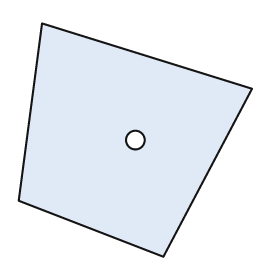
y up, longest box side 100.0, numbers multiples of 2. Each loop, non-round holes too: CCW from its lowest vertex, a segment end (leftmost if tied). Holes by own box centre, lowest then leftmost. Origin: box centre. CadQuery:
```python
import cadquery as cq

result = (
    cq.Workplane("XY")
    .moveTo(12.0, -50.0)
    .lineTo(50.0, 22.0)
    .lineTo(-40.0, 50.0)
    .lineTo(-50.0, -26.0)
    .close()
    .moveTo(0.0, 0.0)
    .circle(4.0)
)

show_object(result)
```